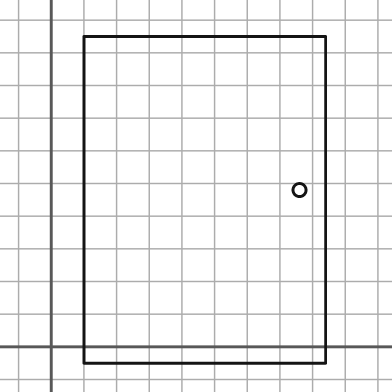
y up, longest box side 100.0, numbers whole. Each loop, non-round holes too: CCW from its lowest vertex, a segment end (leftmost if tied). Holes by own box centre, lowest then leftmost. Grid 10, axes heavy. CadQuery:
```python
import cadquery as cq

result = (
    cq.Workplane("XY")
    .moveTo(10.0, -5.0)
    .lineTo(84.0, -5.0)
    .lineTo(84.0, 95.0)
    .lineTo(10.0, 95.0)
    .close()
    .moveTo(76.0, 48.0)
    .circle(2.0)
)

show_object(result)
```